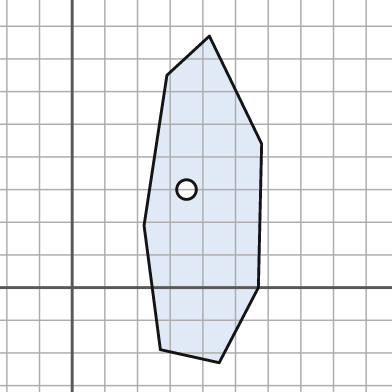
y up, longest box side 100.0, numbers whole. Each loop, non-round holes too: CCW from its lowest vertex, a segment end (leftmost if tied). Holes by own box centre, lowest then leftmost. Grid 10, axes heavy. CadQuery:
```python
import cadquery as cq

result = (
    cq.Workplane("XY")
    .moveTo(45.0, -23.0)
    .lineTo(57.0, 0.0)
    .lineTo(58.0, 44.0)
    .lineTo(42.0, 77.0)
    .lineTo(29.0, 65.0)
    .lineTo(22.0, 19.0)
    .lineTo(27.0, -19.0)
    .close()
    .moveTo(35.0, 30.0)
    .circle(3.0)
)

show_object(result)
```